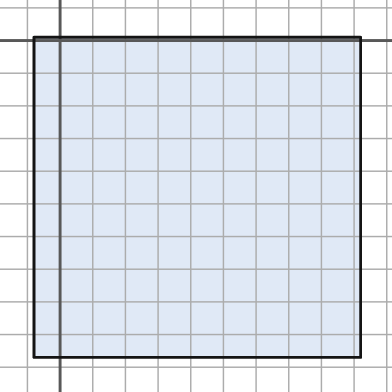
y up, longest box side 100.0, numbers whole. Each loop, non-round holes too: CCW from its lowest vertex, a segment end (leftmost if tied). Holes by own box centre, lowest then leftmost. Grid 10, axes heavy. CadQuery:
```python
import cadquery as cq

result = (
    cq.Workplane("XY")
    .moveTo(-8.0, -97.0)
    .lineTo(92.0, -97.0)
    .lineTo(92.0, 1.0)
    .lineTo(-8.0, 1.0)
    .close()
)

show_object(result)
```